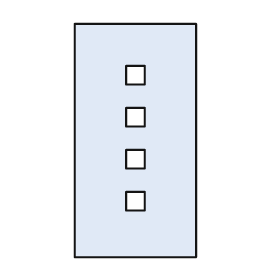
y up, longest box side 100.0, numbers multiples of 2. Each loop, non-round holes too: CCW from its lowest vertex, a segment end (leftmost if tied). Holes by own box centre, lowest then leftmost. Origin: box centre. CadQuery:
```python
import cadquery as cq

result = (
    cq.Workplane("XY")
    .moveTo(-26.0, -50.0)
    .lineTo(26.0, -50.0)
    .lineTo(26.0, 50.0)
    .lineTo(-26.0, 50.0)
    .close()
    .moveTo(-4.0, -30.0)
    .lineTo(4.0, -30.0)
    .lineTo(4.0, -22.0)
    .lineTo(-4.0, -22.0)
    .close()
    .moveTo(-4.0, -12.0)
    .lineTo(4.0, -12.0)
    .lineTo(4.0, -4.0)
    .lineTo(-4.0, -4.0)
    .close()
    .moveTo(-4.0, 6.0)
    .lineTo(4.0, 6.0)
    .lineTo(4.0, 14.0)
    .lineTo(-4.0, 14.0)
    .close()
    .moveTo(-4.0, 24.0)
    .lineTo(4.0, 24.0)
    .lineTo(4.0, 32.0)
    .lineTo(-4.0, 32.0)
    .close()
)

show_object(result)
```